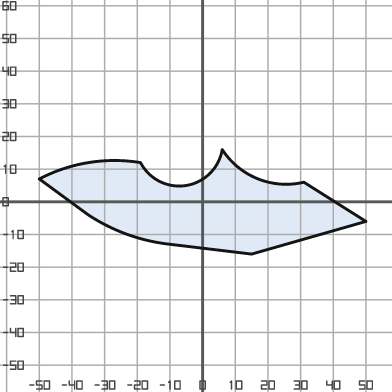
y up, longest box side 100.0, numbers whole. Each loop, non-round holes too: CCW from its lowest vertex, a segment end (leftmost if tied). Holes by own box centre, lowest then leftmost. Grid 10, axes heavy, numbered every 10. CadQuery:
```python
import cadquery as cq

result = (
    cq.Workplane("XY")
    .moveTo(15.0, -16.0)
    .lineTo(50.0, -6.0)
    .lineTo(31.0, 6.0)
    .threePointArc((17.0, 7.0), (6.0, 16.0))
    .threePointArc((-5.0, 5.0), (-19.0, 12.0))
    .threePointArc((-35.0, 12.0), (-50.0, 7.0))
    .lineTo(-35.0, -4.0)
    .threePointArc((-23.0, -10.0), (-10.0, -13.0))
    .close()
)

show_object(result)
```